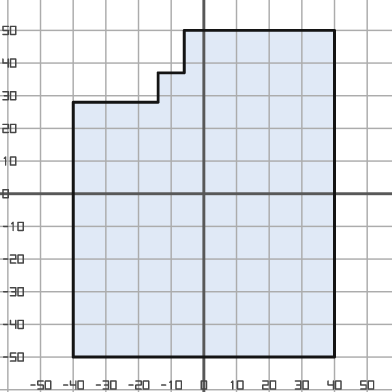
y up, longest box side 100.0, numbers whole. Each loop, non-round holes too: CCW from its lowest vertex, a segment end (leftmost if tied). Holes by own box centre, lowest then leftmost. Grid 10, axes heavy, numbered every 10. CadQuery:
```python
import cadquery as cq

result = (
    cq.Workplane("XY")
    .moveTo(-40.0, -50.0)
    .lineTo(40.0, -50.0)
    .lineTo(40.0, 50.0)
    .lineTo(-6.0, 50.0)
    .lineTo(-6.0, 37.0)
    .lineTo(-14.0, 37.0)
    .lineTo(-14.0, 28.0)
    .lineTo(-40.0, 28.0)
    .close()
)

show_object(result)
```